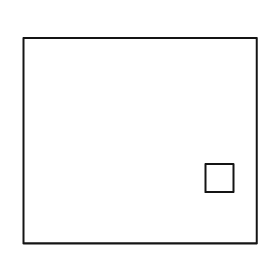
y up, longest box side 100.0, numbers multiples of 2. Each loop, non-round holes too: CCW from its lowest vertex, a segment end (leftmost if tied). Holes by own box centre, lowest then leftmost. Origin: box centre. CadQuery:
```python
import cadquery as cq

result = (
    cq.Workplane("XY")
    .moveTo(-50.0, -44.0)
    .lineTo(50.0, -44.0)
    .lineTo(50.0, 44.0)
    .lineTo(-50.0, 44.0)
    .close()
    .moveTo(28.0, -22.0)
    .lineTo(40.0, -22.0)
    .lineTo(40.0, -10.0)
    .lineTo(28.0, -10.0)
    .close()
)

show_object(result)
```